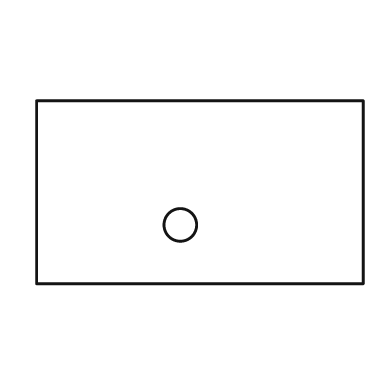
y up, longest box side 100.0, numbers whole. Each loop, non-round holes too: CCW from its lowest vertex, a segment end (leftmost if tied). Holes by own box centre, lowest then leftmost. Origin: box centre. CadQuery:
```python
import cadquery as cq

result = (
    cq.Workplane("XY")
    .moveTo(-50.0, -28.0)
    .lineTo(50.0, -28.0)
    .lineTo(50.0, 28.0)
    .lineTo(-50.0, 28.0)
    .close()
    .moveTo(-6.0, -10.0)
    .circle(5.0)
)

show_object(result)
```